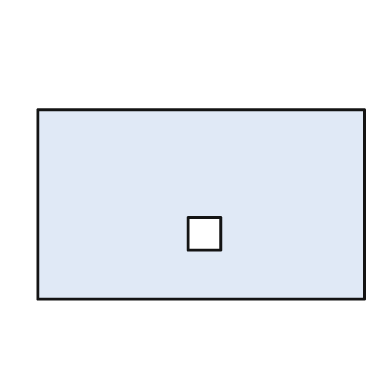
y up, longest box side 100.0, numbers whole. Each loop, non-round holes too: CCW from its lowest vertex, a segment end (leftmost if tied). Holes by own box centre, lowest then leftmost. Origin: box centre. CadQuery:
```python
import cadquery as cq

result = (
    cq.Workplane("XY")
    .moveTo(-50.0, -29.0)
    .lineTo(50.0, -29.0)
    .lineTo(50.0, 29.0)
    .lineTo(-50.0, 29.0)
    .close()
    .moveTo(-4.0, -14.0)
    .lineTo(6.0, -14.0)
    .lineTo(6.0, -4.0)
    .lineTo(-4.0, -4.0)
    .close()
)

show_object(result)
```